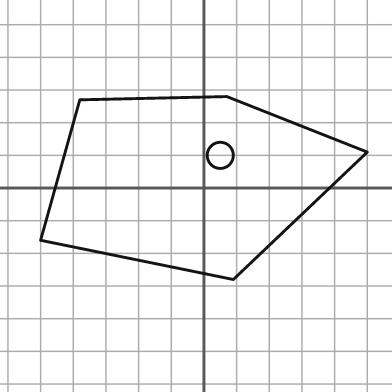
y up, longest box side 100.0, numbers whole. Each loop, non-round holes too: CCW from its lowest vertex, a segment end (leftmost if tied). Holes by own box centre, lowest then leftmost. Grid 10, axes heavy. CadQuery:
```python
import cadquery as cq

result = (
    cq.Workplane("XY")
    .moveTo(9.0, -28.0)
    .lineTo(50.0, 11.0)
    .lineTo(7.0, 28.0)
    .lineTo(-38.0, 27.0)
    .lineTo(-50.0, -16.0)
    .close()
    .moveTo(5.0, 10.0)
    .circle(4.0)
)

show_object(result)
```